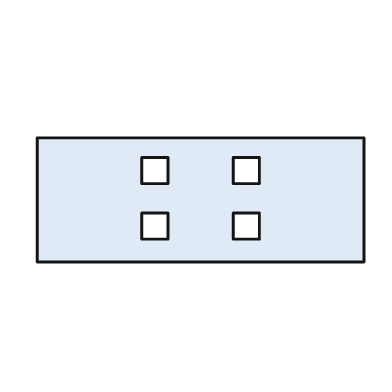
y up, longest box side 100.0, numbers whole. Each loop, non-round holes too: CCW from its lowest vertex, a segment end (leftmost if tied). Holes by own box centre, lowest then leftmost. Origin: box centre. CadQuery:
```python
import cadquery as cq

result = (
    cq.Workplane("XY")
    .moveTo(-50.0, -19.0)
    .lineTo(50.0, -19.0)
    .lineTo(50.0, 19.0)
    .lineTo(-50.0, 19.0)
    .close()
    .moveTo(-18.0, -12.0)
    .lineTo(-10.0, -12.0)
    .lineTo(-10.0, -4.0)
    .lineTo(-18.0, -4.0)
    .close()
    .moveTo(10.0, -12.0)
    .lineTo(18.0, -12.0)
    .lineTo(18.0, -4.0)
    .lineTo(10.0, -4.0)
    .close()
    .moveTo(-18.0, 5.0)
    .lineTo(-10.0, 5.0)
    .lineTo(-10.0, 13.0)
    .lineTo(-18.0, 13.0)
    .close()
    .moveTo(10.0, 5.0)
    .lineTo(18.0, 5.0)
    .lineTo(18.0, 13.0)
    .lineTo(10.0, 13.0)
    .close()
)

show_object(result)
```